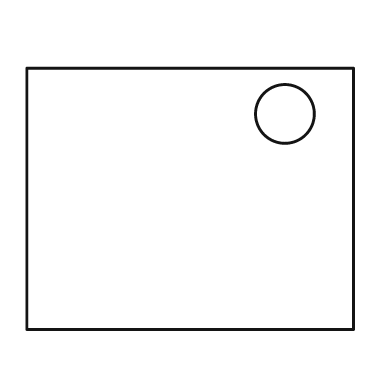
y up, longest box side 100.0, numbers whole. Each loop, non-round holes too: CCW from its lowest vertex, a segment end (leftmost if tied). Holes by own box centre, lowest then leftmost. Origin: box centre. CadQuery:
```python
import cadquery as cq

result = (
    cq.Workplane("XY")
    .moveTo(-50.0, -40.0)
    .lineTo(50.0, -40.0)
    .lineTo(50.0, 40.0)
    .lineTo(-50.0, 40.0)
    .close()
    .moveTo(29.0, 26.0)
    .circle(9.0)
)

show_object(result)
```